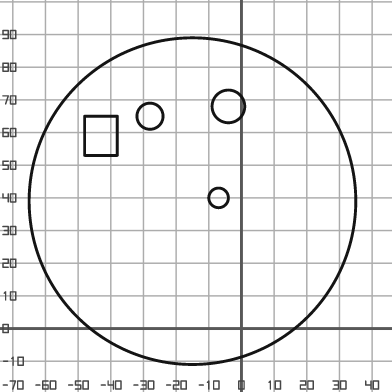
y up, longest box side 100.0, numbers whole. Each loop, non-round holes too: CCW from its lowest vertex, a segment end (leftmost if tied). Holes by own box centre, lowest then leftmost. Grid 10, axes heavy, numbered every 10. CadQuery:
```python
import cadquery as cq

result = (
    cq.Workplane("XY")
    .moveTo(-15.0, 39.0)
    .circle(50.0)
    .moveTo(-7.0, 40.0)
    .circle(3.0)
    .moveTo(-48.0, 53.0)
    .lineTo(-38.0, 53.0)
    .lineTo(-38.0, 65.0)
    .lineTo(-48.0, 65.0)
    .close()
    .moveTo(-28.0, 65.0)
    .circle(4.0)
    .moveTo(-4.0, 68.0)
    .circle(5.0)
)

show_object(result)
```